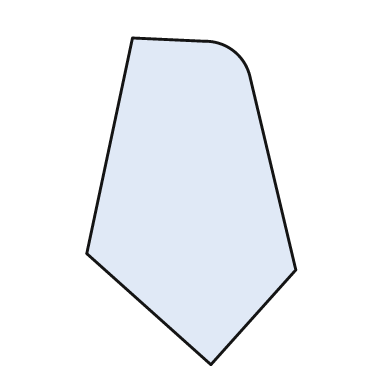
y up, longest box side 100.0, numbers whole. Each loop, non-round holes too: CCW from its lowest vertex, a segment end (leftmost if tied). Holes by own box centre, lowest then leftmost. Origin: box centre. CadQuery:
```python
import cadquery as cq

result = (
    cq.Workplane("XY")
    .moveTo(6.0, -50.0)
    .lineTo(32.0, -21.0)
    .lineTo(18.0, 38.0)
    .threePointArc((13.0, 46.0), (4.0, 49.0))
    .lineTo(-18.0, 50.0)
    .lineTo(-32.0, -16.0)
    .close()
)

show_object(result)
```